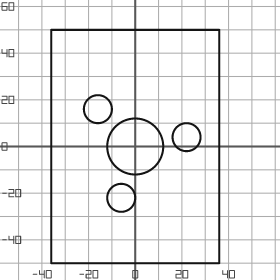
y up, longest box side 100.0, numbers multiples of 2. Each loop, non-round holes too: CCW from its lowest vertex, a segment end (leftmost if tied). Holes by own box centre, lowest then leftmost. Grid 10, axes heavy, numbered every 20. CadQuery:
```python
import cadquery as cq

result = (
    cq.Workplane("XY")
    .moveTo(-36.0, -50.0)
    .lineTo(36.0, -50.0)
    .lineTo(36.0, 50.0)
    .lineTo(-36.0, 50.0)
    .close()
    .moveTo(-6.0, -22.0)
    .circle(6.0)
    .moveTo(0.0, 0.0)
    .circle(12.0)
    .moveTo(22.0, 4.0)
    .circle(6.0)
    .moveTo(-16.0, 16.0)
    .circle(6.0)
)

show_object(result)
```